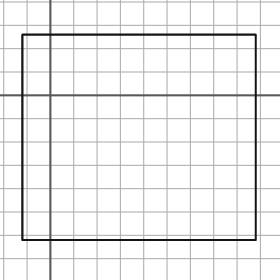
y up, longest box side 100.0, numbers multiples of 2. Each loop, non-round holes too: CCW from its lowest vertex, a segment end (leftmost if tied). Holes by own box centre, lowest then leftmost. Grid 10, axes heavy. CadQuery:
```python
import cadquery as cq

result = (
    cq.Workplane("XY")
    .moveTo(-12.0, -62.0)
    .lineTo(88.0, -62.0)
    .lineTo(88.0, 26.0)
    .lineTo(-12.0, 26.0)
    .close()
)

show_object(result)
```